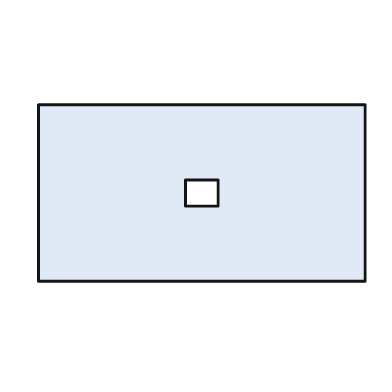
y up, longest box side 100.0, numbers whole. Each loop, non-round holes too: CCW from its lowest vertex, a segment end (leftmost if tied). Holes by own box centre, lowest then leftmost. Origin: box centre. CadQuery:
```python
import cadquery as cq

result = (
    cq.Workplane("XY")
    .moveTo(-50.0, -27.0)
    .lineTo(50.0, -27.0)
    .lineTo(50.0, 27.0)
    .lineTo(-50.0, 27.0)
    .close()
    .moveTo(-5.0, -4.0)
    .lineTo(5.0, -4.0)
    .lineTo(5.0, 4.0)
    .lineTo(-5.0, 4.0)
    .close()
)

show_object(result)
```